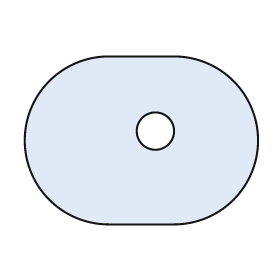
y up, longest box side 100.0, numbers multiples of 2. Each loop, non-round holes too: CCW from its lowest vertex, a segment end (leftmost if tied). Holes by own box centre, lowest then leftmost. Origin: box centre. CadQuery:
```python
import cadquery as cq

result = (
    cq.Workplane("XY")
    .moveTo(-14.0, -36.0)
    .lineTo(14.0, -36.0)
    .threePointArc((50.0, 0.0), (14.0, 36.0))
    .lineTo(-14.0, 36.0)
    .threePointArc((-50.0, 0.0), (-14.0, -36.0))
    .close()
    .moveTo(6.0, 4.0)
    .circle(8.0)
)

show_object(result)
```